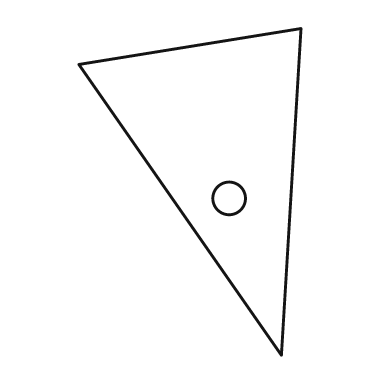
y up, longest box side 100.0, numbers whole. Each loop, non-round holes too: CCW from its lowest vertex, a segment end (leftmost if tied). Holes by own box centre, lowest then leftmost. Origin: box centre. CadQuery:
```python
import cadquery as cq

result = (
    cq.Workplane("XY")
    .moveTo(28.0, -50.0)
    .lineTo(34.0, 50.0)
    .lineTo(-34.0, 39.0)
    .close()
    .moveTo(12.0, -2.0)
    .circle(5.0)
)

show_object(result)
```